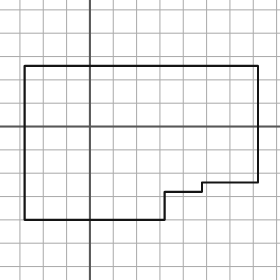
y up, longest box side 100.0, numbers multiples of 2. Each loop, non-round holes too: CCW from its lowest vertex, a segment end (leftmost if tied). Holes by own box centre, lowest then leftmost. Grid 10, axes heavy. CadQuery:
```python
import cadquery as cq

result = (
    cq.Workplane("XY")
    .moveTo(-28.0, -40.0)
    .lineTo(32.0, -40.0)
    .lineTo(32.0, -28.0)
    .lineTo(48.0, -28.0)
    .lineTo(48.0, -24.0)
    .lineTo(72.0, -24.0)
    .lineTo(72.0, 26.0)
    .lineTo(-28.0, 26.0)
    .close()
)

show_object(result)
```